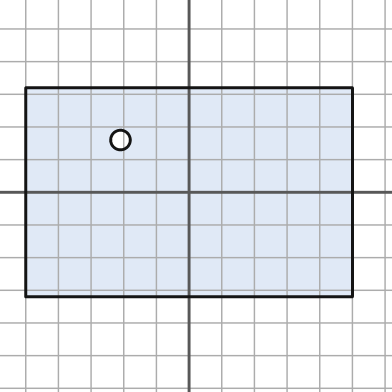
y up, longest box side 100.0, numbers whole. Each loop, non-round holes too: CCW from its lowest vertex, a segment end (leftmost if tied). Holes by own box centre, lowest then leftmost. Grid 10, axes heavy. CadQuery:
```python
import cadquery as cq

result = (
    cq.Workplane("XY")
    .moveTo(-50.0, -32.0)
    .lineTo(50.0, -32.0)
    .lineTo(50.0, 32.0)
    .lineTo(-50.0, 32.0)
    .close()
    .moveTo(-21.0, 16.0)
    .circle(3.0)
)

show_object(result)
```